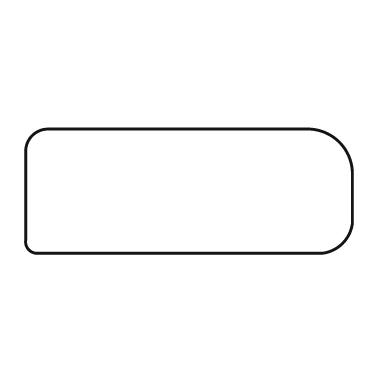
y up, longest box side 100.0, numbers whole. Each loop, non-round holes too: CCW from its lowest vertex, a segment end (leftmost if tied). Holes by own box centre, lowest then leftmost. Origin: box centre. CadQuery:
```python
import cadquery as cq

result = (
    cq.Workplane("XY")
    .moveTo(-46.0, -19.0)
    .lineTo(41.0, -19.0)
    .threePointArc((47.0, -16.0), (50.0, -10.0))
    .lineTo(50.0, 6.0)
    .threePointArc((46.0, 15.0), (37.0, 19.0))
    .lineTo(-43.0, 19.0)
    .threePointArc((-48.0, 17.0), (-50.0, 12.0))
    .lineTo(-50.0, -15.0)
    .threePointArc((-49.0, -18.0), (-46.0, -19.0))
    .close()
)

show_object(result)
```